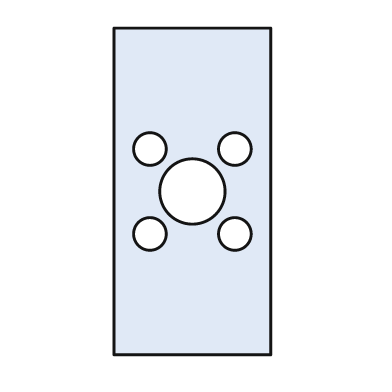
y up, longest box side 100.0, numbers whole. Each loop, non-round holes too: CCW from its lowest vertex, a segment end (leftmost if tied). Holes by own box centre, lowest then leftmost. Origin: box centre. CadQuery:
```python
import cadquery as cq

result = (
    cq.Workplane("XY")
    .moveTo(-24.0, -50.0)
    .lineTo(24.0, -50.0)
    .lineTo(24.0, 50.0)
    .lineTo(-24.0, 50.0)
    .close()
    .moveTo(-13.0, -13.0)
    .circle(5.0)
    .moveTo(13.0, -13.0)
    .circle(5.0)
    .moveTo(0.0, 0.0)
    .circle(10.0)
    .moveTo(-13.0, 13.0)
    .circle(5.0)
    .moveTo(13.0, 13.0)
    .circle(5.0)
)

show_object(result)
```